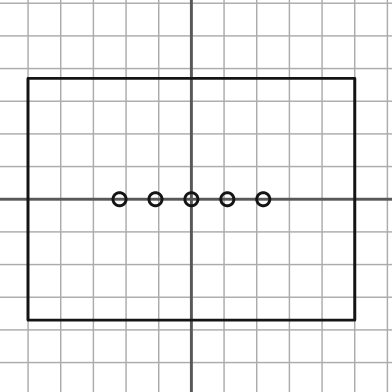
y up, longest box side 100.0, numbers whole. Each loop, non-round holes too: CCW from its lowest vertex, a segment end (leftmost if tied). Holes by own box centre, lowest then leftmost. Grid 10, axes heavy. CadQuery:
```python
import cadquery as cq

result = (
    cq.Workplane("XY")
    .moveTo(-50.0, -37.0)
    .lineTo(50.0, -37.0)
    .lineTo(50.0, 37.0)
    .lineTo(-50.0, 37.0)
    .close()
    .moveTo(-22.0, 0.0)
    .circle(2.0)
    .moveTo(-11.0, 0.0)
    .circle(2.0)
    .moveTo(0.0, 0.0)
    .circle(2.0)
    .moveTo(11.0, 0.0)
    .circle(2.0)
    .moveTo(22.0, 0.0)
    .circle(2.0)
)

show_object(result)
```